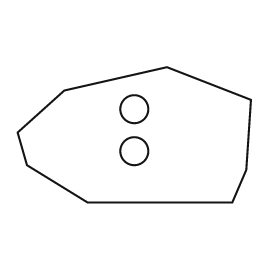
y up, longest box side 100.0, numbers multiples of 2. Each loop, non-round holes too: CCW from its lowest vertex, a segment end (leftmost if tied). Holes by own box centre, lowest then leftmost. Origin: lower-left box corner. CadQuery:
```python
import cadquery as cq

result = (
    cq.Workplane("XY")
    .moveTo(30.0, 0.0)
    .lineTo(92.0, 0.0)
    .lineTo(98.0, 14.0)
    .lineTo(100.0, 44.0)
    .lineTo(64.0, 58.0)
    .lineTo(20.0, 48.0)
    .lineTo(0.0, 30.0)
    .lineTo(4.0, 16.0)
    .close()
    .moveTo(50.0, 22.0)
    .circle(6.0)
    .moveTo(50.0, 40.0)
    .circle(6.0)
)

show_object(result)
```